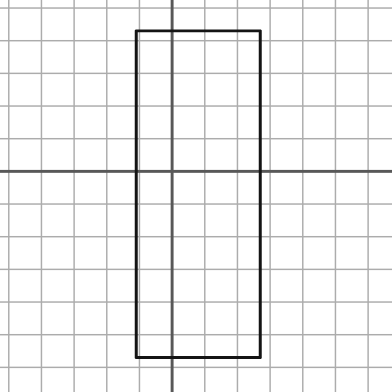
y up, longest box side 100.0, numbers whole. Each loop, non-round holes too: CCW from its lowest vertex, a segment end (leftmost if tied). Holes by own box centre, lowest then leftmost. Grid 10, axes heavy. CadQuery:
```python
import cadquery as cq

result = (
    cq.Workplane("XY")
    .moveTo(-11.0, -57.0)
    .lineTo(27.0, -57.0)
    .lineTo(27.0, 43.0)
    .lineTo(-11.0, 43.0)
    .close()
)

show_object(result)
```